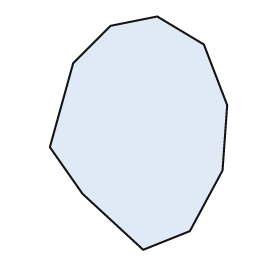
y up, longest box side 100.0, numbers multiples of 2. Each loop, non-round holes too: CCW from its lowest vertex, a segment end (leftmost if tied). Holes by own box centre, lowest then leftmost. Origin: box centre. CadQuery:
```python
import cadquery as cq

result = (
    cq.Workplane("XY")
    .moveTo(2.0, -50.0)
    .lineTo(22.0, -42.0)
    .lineTo(36.0, -16.0)
    .lineTo(38.0, 12.0)
    .lineTo(28.0, 38.0)
    .lineTo(8.0, 50.0)
    .lineTo(-12.0, 46.0)
    .lineTo(-28.0, 30.0)
    .lineTo(-38.0, -6.0)
    .lineTo(-24.0, -26.0)
    .close()
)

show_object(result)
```